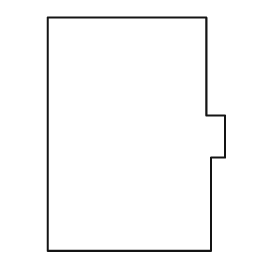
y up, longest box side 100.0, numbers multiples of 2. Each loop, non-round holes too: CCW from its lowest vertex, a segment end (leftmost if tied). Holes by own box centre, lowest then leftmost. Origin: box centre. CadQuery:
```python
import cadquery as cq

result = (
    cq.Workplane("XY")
    .moveTo(-38.0, -50.0)
    .lineTo(32.0, -50.0)
    .lineTo(32.0, -10.0)
    .lineTo(38.0, -10.0)
    .lineTo(38.0, 8.0)
    .lineTo(30.0, 8.0)
    .lineTo(30.0, 50.0)
    .lineTo(-38.0, 50.0)
    .close()
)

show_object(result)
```